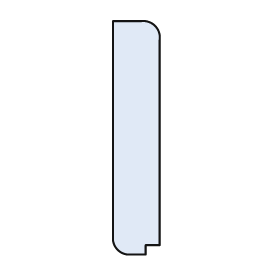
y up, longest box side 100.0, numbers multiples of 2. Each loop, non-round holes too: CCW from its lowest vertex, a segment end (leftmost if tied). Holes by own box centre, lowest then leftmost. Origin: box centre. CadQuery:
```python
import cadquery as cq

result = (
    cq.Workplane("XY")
    .moveTo(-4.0, -50.0)
    .lineTo(4.0, -50.0)
    .lineTo(4.0, -46.0)
    .lineTo(10.0, -46.0)
    .lineTo(10.0, 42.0)
    .threePointArc((8.0, 48.0), (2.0, 50.0))
    .lineTo(-10.0, 50.0)
    .lineTo(-10.0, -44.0)
    .threePointArc((-8.0, -48.0), (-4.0, -50.0))
    .close()
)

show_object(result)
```